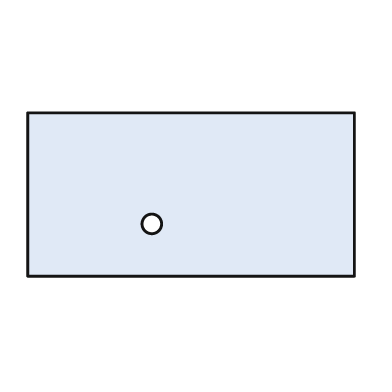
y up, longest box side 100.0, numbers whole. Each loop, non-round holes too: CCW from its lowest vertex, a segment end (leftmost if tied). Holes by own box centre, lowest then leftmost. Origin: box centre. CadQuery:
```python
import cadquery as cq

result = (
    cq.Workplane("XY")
    .moveTo(-50.0, -25.0)
    .lineTo(50.0, -25.0)
    .lineTo(50.0, 25.0)
    .lineTo(-50.0, 25.0)
    .close()
    .moveTo(-12.0, -9.0)
    .circle(3.0)
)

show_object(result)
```